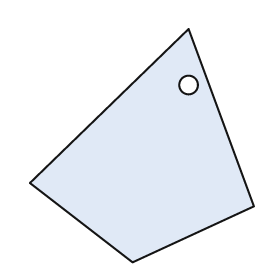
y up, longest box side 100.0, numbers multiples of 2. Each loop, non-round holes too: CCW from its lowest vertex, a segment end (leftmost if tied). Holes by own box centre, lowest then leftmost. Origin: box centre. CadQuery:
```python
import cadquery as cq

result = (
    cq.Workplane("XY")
    .moveTo(-4.0, -50.0)
    .lineTo(48.0, -26.0)
    .lineTo(20.0, 50.0)
    .lineTo(-48.0, -16.0)
    .close()
    .moveTo(20.0, 26.0)
    .circle(4.0)
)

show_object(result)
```